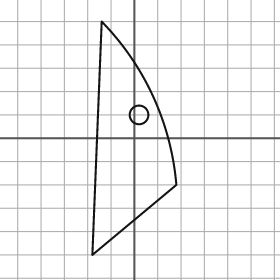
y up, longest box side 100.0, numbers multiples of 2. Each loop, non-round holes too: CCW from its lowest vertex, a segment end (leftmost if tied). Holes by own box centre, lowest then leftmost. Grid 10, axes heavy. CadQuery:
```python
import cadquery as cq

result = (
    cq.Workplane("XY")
    .moveTo(-18.0, -50.0)
    .lineTo(18.0, -20.0)
    .threePointArc((8.0, 18.0), (-14.0, 50.0))
    .close()
    .moveTo(2.0, 10.0)
    .circle(4.0)
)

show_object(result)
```